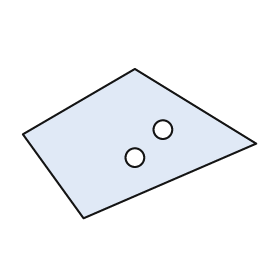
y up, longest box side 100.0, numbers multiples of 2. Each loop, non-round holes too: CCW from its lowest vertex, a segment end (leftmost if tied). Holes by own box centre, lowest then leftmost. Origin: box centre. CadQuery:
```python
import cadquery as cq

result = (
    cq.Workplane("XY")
    .moveTo(-24.0, -32.0)
    .lineTo(50.0, 0.0)
    .lineTo(-2.0, 32.0)
    .lineTo(-50.0, 4.0)
    .close()
    .moveTo(-2.0, -6.0)
    .circle(4.0)
    .moveTo(10.0, 6.0)
    .circle(4.0)
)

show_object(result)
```